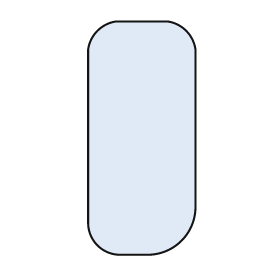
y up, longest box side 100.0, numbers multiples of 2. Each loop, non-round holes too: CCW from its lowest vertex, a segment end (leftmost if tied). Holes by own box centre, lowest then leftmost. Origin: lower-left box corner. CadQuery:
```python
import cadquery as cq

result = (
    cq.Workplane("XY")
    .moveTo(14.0, 0.0)
    .lineTo(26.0, 0.0)
    .threePointArc((40.0, 6.0), (46.0, 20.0))
    .lineTo(46.0, 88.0)
    .threePointArc((42.0, 96.0), (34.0, 100.0))
    .lineTo(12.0, 100.0)
    .threePointArc((4.0, 96.0), (0.0, 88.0))
    .lineTo(0.0, 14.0)
    .threePointArc((4.0, 4.0), (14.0, 0.0))
    .close()
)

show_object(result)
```